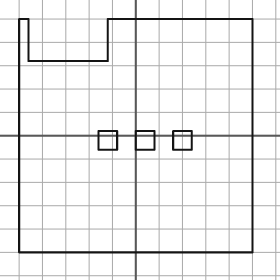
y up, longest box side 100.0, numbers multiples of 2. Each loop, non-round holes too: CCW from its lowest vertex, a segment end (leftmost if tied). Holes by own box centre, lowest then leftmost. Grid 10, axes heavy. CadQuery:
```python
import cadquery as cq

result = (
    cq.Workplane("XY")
    .moveTo(-50.0, -50.0)
    .lineTo(50.0, -50.0)
    .lineTo(50.0, 50.0)
    .lineTo(-12.0, 50.0)
    .lineTo(-12.0, 32.0)
    .lineTo(-46.0, 32.0)
    .lineTo(-46.0, 50.0)
    .lineTo(-50.0, 50.0)
    .close()
    .moveTo(-16.0, -6.0)
    .lineTo(-8.0, -6.0)
    .lineTo(-8.0, 2.0)
    .lineTo(-16.0, 2.0)
    .close()
    .moveTo(0.0, -6.0)
    .lineTo(8.0, -6.0)
    .lineTo(8.0, 2.0)
    .lineTo(0.0, 2.0)
    .close()
    .moveTo(16.0, -6.0)
    .lineTo(24.0, -6.0)
    .lineTo(24.0, 2.0)
    .lineTo(16.0, 2.0)
    .close()
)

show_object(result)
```